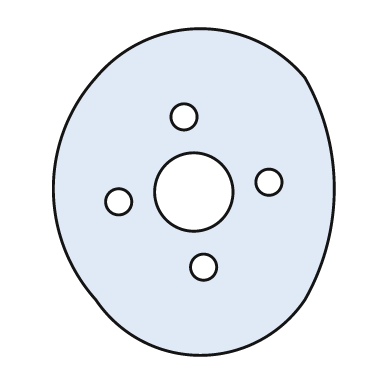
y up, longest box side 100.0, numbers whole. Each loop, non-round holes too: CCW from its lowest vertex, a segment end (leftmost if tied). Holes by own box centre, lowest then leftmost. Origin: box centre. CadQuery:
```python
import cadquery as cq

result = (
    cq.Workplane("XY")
    .moveTo(-30.0, -33.0)
    .threePointArc((2.0, -50.0), (34.0, -33.0))
    .threePointArc((43.0, 1.0), (34.0, 35.0))
    .threePointArc((2.0, 50.0), (-30.0, 35.0))
    .threePointArc((-43.0, 1.0), (-30.0, -33.0))
    .close()
    .moveTo(3.0, -23.0)
    .circle(4.0)
    .moveTo(-23.0, -3.0)
    .circle(4.0)
    .moveTo(0.0, 0.0)
    .circle(12.0)
    .moveTo(23.0, 3.0)
    .circle(4.0)
    .moveTo(-3.0, 23.0)
    .circle(4.0)
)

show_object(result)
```